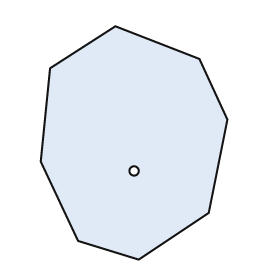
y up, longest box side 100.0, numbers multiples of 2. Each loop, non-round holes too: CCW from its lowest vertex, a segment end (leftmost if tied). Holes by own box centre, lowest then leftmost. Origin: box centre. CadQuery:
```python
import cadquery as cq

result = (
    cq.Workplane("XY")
    .moveTo(2.0, -50.0)
    .lineTo(32.0, -30.0)
    .lineTo(40.0, 10.0)
    .lineTo(28.0, 36.0)
    .lineTo(-8.0, 50.0)
    .lineTo(-36.0, 32.0)
    .lineTo(-40.0, -8.0)
    .lineTo(-24.0, -42.0)
    .close()
    .moveTo(0.0, -12.0)
    .circle(2.0)
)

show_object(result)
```